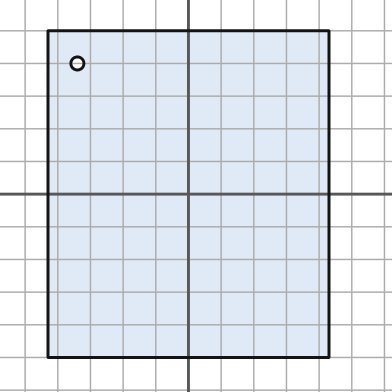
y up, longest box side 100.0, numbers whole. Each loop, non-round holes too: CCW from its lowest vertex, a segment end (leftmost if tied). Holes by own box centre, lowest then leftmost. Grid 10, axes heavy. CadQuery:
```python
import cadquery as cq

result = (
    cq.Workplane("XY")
    .moveTo(-43.0, -50.0)
    .lineTo(43.0, -50.0)
    .lineTo(43.0, 50.0)
    .lineTo(-43.0, 50.0)
    .close()
    .moveTo(-34.0, 40.0)
    .circle(2.0)
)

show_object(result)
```